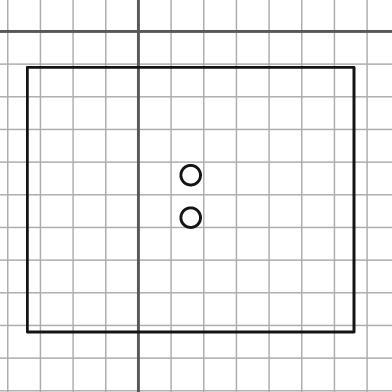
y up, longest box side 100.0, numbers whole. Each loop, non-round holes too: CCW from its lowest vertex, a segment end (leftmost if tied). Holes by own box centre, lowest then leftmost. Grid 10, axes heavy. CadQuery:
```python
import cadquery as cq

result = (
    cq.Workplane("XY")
    .moveTo(-34.0, -92.0)
    .lineTo(66.0, -92.0)
    .lineTo(66.0, -11.0)
    .lineTo(-34.0, -11.0)
    .close()
    .moveTo(16.0, -57.0)
    .circle(3.0)
    .moveTo(16.0, -44.0)
    .circle(3.0)
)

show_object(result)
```